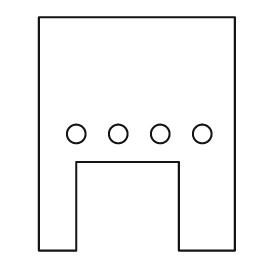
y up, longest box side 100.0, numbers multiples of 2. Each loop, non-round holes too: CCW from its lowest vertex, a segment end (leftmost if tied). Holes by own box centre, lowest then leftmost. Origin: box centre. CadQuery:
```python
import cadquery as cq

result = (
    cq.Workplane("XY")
    .moveTo(-42.0, -50.0)
    .lineTo(-26.0, -50.0)
    .lineTo(-26.0, -12.0)
    .lineTo(18.0, -12.0)
    .lineTo(18.0, -50.0)
    .lineTo(42.0, -50.0)
    .lineTo(42.0, 50.0)
    .lineTo(-42.0, 50.0)
    .close()
    .moveTo(-26.0, 0.0)
    .circle(4.0)
    .moveTo(-8.0, 0.0)
    .circle(4.0)
    .moveTo(10.0, 0.0)
    .circle(4.0)
    .moveTo(28.0, 0.0)
    .circle(4.0)
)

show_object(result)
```